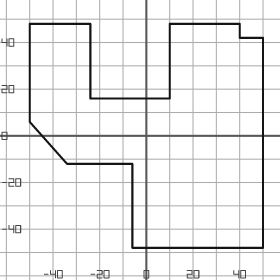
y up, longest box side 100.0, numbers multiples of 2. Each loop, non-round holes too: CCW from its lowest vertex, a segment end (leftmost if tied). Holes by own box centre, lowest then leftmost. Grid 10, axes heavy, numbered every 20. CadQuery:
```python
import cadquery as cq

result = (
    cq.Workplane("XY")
    .moveTo(-6.0, -48.0)
    .lineTo(50.0, -48.0)
    .lineTo(50.0, 42.0)
    .lineTo(40.0, 42.0)
    .lineTo(40.0, 48.0)
    .lineTo(10.0, 48.0)
    .lineTo(10.0, 16.0)
    .lineTo(-24.0, 16.0)
    .lineTo(-24.0, 48.0)
    .lineTo(-50.0, 48.0)
    .lineTo(-50.0, 6.0)
    .lineTo(-34.0, -12.0)
    .lineTo(-6.0, -12.0)
    .close()
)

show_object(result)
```